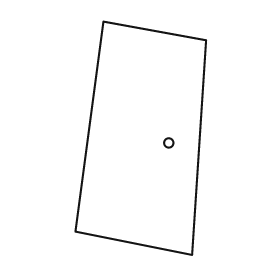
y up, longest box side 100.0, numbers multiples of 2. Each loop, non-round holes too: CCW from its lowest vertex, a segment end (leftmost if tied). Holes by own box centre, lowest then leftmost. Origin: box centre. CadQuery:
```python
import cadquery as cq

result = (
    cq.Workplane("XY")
    .moveTo(22.0, -50.0)
    .lineTo(28.0, 42.0)
    .lineTo(-16.0, 50.0)
    .lineTo(-28.0, -40.0)
    .close()
    .moveTo(12.0, -2.0)
    .circle(2.0)
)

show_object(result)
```